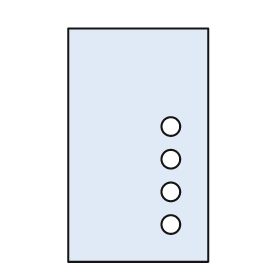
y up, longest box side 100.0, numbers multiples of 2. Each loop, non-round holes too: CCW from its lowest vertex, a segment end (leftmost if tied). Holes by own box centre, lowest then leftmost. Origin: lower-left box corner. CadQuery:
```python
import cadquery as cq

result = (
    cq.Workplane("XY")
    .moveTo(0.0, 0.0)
    .lineTo(60.0, 0.0)
    .lineTo(60.0, 100.0)
    .lineTo(0.0, 100.0)
    .close()
    .moveTo(44.0, 16.0)
    .circle(4.0)
    .moveTo(44.0, 30.0)
    .circle(4.0)
    .moveTo(44.0, 44.0)
    .circle(4.0)
    .moveTo(44.0, 58.0)
    .circle(4.0)
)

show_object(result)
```